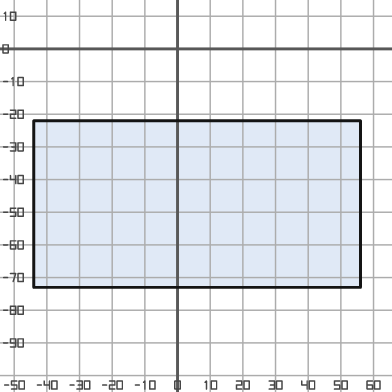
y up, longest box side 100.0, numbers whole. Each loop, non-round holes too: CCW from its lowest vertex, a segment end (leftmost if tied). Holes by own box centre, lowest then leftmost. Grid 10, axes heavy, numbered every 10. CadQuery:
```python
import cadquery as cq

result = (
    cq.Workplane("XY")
    .moveTo(-44.0, -73.0)
    .lineTo(56.0, -73.0)
    .lineTo(56.0, -22.0)
    .lineTo(-44.0, -22.0)
    .close()
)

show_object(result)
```